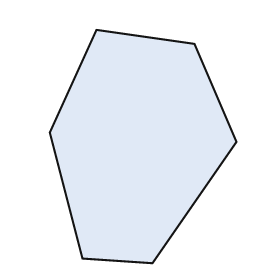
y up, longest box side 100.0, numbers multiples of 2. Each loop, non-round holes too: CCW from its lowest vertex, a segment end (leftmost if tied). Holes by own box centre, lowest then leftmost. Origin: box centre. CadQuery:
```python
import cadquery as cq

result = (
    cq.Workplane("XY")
    .moveTo(4.0, -50.0)
    .lineTo(40.0, 2.0)
    .lineTo(22.0, 44.0)
    .lineTo(-20.0, 50.0)
    .lineTo(-40.0, 6.0)
    .lineTo(-26.0, -48.0)
    .close()
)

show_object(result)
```